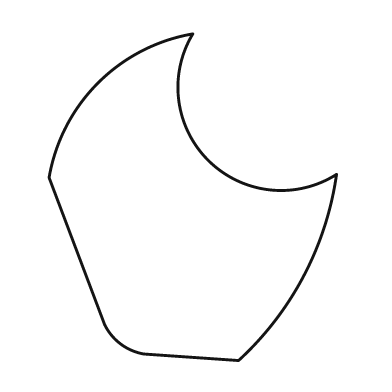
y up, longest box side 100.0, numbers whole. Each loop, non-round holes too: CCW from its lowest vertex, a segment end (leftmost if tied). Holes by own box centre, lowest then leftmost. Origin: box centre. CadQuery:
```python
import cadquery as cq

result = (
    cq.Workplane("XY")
    .moveTo(14.0, -50.0)
    .threePointArc((34.0, -24.0), (44.0, 7.0))
    .threePointArc((5.0, 11.0), (0.0, 50.0))
    .threePointArc((-29.0, 35.0), (-44.0, 6.0))
    .lineTo(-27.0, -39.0)
    .threePointArc((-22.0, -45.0), (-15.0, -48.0))
    .close()
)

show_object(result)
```